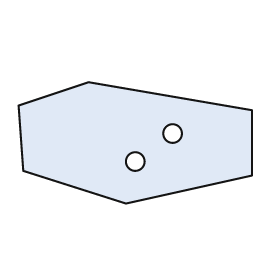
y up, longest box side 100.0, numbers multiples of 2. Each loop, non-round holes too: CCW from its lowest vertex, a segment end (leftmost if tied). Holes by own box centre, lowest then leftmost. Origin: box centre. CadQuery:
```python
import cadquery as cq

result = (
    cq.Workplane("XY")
    .moveTo(-4.0, -26.0)
    .lineTo(50.0, -14.0)
    .lineTo(50.0, 14.0)
    .lineTo(-20.0, 26.0)
    .lineTo(-50.0, 16.0)
    .lineTo(-48.0, -12.0)
    .close()
    .moveTo(0.0, -8.0)
    .circle(4.0)
    .moveTo(16.0, 4.0)
    .circle(4.0)
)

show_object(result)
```